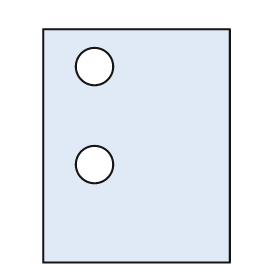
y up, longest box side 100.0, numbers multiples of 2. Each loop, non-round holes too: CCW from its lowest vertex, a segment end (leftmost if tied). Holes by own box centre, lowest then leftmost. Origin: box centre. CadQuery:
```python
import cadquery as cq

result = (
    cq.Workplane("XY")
    .moveTo(-40.0, -50.0)
    .lineTo(40.0, -50.0)
    .lineTo(40.0, 50.0)
    .lineTo(-40.0, 50.0)
    .close()
    .moveTo(-18.0, -8.0)
    .circle(8.0)
    .moveTo(-18.0, 34.0)
    .circle(8.0)
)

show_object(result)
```